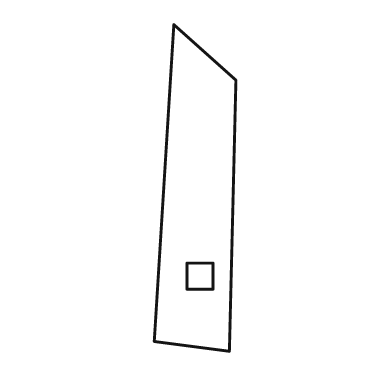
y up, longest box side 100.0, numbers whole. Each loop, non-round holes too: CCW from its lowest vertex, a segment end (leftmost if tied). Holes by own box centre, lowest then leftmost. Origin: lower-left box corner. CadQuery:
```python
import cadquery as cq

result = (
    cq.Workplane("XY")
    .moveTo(23.0, 0.0)
    .lineTo(25.0, 83.0)
    .lineTo(6.0, 100.0)
    .lineTo(0.0, 3.0)
    .close()
    .moveTo(10.0, 19.0)
    .lineTo(18.0, 19.0)
    .lineTo(18.0, 27.0)
    .lineTo(10.0, 27.0)
    .close()
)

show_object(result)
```